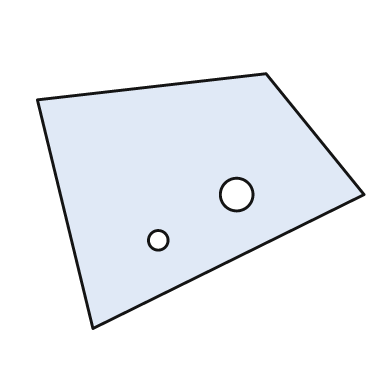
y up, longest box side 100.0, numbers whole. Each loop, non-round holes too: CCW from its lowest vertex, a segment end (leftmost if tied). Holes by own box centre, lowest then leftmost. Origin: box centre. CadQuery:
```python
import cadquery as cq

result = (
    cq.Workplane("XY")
    .moveTo(-33.0, -39.0)
    .lineTo(50.0, 2.0)
    .lineTo(20.0, 39.0)
    .lineTo(-50.0, 31.0)
    .close()
    .moveTo(-13.0, -12.0)
    .circle(3.0)
    .moveTo(11.0, 2.0)
    .circle(5.0)
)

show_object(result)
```